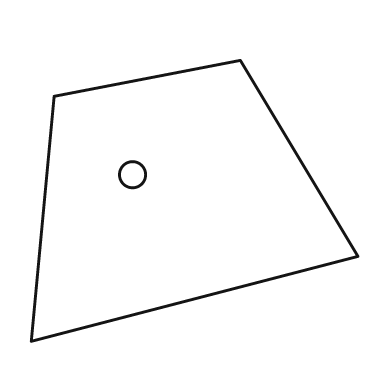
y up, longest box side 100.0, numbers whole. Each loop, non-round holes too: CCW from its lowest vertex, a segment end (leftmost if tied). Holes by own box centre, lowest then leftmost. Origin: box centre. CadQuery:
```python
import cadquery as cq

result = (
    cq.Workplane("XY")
    .moveTo(-50.0, -43.0)
    .lineTo(50.0, -17.0)
    .lineTo(14.0, 43.0)
    .lineTo(-43.0, 32.0)
    .close()
    .moveTo(-19.0, 8.0)
    .circle(4.0)
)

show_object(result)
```